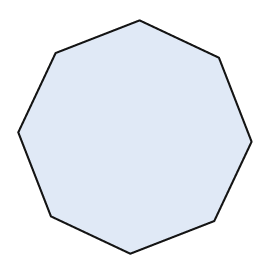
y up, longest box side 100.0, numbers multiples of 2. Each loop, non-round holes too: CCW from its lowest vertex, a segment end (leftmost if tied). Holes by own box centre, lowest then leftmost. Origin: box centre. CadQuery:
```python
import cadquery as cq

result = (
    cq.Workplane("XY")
    .moveTo(-2.0, -50.0)
    .lineTo(34.0, -36.0)
    .lineTo(50.0, -2.0)
    .lineTo(36.0, 34.0)
    .lineTo(2.0, 50.0)
    .lineTo(-34.0, 36.0)
    .lineTo(-50.0, 2.0)
    .lineTo(-36.0, -34.0)
    .close()
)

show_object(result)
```